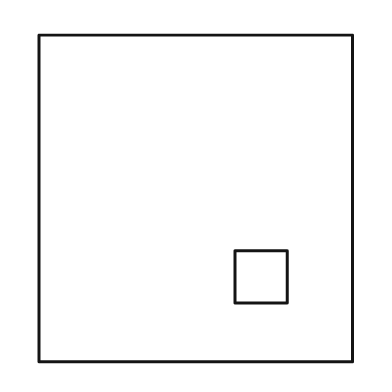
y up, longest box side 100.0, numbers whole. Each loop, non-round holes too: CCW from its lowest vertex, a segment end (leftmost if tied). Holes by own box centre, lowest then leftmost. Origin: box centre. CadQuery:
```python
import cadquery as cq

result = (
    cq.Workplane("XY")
    .moveTo(-48.0, -50.0)
    .lineTo(48.0, -50.0)
    .lineTo(48.0, 50.0)
    .lineTo(-48.0, 50.0)
    .close()
    .moveTo(12.0, -32.0)
    .lineTo(28.0, -32.0)
    .lineTo(28.0, -16.0)
    .lineTo(12.0, -16.0)
    .close()
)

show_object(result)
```